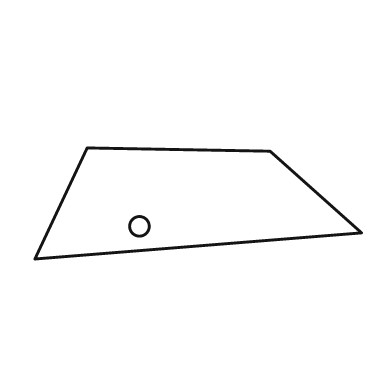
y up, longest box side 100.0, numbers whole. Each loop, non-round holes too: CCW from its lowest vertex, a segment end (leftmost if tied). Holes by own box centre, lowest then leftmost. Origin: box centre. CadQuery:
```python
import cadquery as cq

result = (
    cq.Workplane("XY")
    .moveTo(-50.0, -17.0)
    .lineTo(50.0, -9.0)
    .lineTo(22.0, 16.0)
    .lineTo(-34.0, 17.0)
    .close()
    .moveTo(-18.0, -7.0)
    .circle(3.0)
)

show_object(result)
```